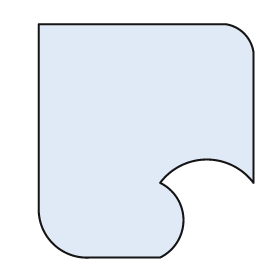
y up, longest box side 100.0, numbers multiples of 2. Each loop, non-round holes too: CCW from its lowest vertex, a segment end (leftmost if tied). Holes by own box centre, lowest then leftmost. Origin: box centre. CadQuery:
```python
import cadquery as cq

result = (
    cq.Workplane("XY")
    .moveTo(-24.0, -50.0)
    .lineTo(6.0, -50.0)
    .threePointArc((16.0, -34.0), (6.0, -18.0))
    .threePointArc((26.0, -8.0), (46.0, -18.0))
    .lineTo(46.0, 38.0)
    .threePointArc((42.0, 46.0), (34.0, 50.0))
    .lineTo(-46.0, 50.0)
    .lineTo(-46.0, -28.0)
    .threePointArc((-40.0, -44.0), (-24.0, -50.0))
    .close()
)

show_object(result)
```